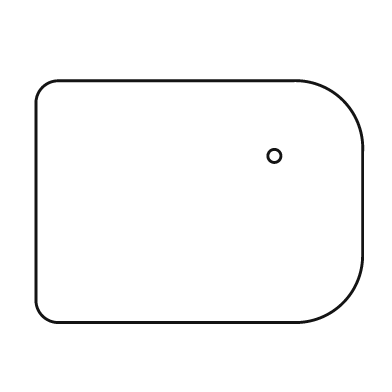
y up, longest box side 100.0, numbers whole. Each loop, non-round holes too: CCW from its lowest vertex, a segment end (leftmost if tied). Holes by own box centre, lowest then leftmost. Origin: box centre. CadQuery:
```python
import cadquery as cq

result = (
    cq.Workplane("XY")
    .moveTo(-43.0, -37.0)
    .lineTo(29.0, -37.0)
    .threePointArc((44.0, -31.0), (50.0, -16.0))
    .lineTo(50.0, 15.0)
    .threePointArc((44.0, 31.0), (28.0, 37.0))
    .lineTo(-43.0, 37.0)
    .threePointArc((-48.0, 35.0), (-50.0, 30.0))
    .lineTo(-50.0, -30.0)
    .threePointArc((-48.0, -35.0), (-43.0, -37.0))
    .close()
    .moveTo(23.0, 14.0)
    .circle(2.0)
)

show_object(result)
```